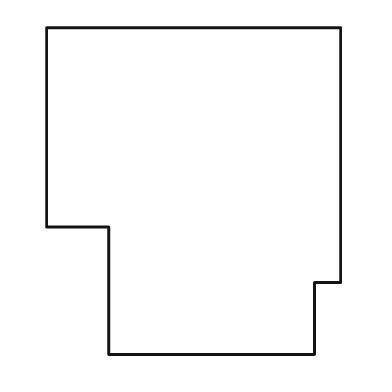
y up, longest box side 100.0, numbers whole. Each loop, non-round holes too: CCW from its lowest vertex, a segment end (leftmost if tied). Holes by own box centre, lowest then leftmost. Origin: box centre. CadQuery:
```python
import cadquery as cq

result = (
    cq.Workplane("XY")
    .moveTo(-26.0, -50.0)
    .lineTo(37.0, -50.0)
    .lineTo(37.0, -28.0)
    .lineTo(45.0, -28.0)
    .lineTo(45.0, 50.0)
    .lineTo(-45.0, 50.0)
    .lineTo(-45.0, -11.0)
    .lineTo(-26.0, -11.0)
    .close()
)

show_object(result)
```